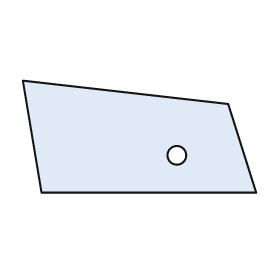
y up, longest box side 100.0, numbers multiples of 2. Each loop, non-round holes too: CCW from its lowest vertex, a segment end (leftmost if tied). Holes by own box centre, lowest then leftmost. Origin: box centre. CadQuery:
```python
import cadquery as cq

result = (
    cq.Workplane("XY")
    .moveTo(-42.0, -24.0)
    .lineTo(50.0, -24.0)
    .lineTo(38.0, 14.0)
    .lineTo(-50.0, 24.0)
    .close()
    .moveTo(16.0, -8.0)
    .circle(4.0)
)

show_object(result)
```